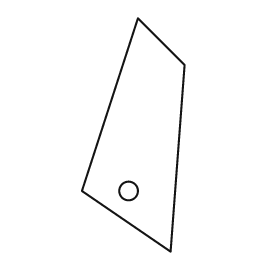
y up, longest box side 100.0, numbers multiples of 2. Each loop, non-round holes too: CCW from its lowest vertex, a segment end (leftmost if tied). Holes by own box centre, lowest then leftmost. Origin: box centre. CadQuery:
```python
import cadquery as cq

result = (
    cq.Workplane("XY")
    .moveTo(16.0, -50.0)
    .lineTo(22.0, 30.0)
    .lineTo(2.0, 50.0)
    .lineTo(-22.0, -24.0)
    .close()
    .moveTo(-2.0, -24.0)
    .circle(4.0)
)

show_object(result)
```